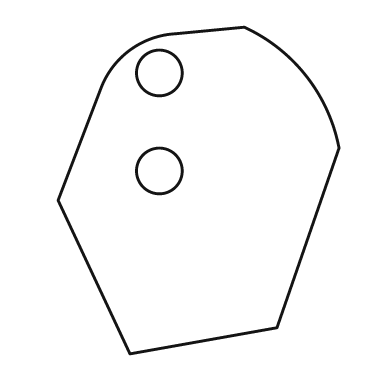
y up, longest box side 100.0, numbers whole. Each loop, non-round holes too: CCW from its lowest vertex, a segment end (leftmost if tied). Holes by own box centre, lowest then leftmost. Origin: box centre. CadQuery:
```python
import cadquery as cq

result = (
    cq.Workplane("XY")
    .moveTo(-21.0, -50.0)
    .lineTo(24.0, -42.0)
    .lineTo(43.0, 13.0)
    .threePointArc((33.0, 35.0), (14.0, 50.0))
    .lineTo(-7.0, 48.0)
    .threePointArc((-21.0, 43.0), (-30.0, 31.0))
    .lineTo(-43.0, -3.0)
    .close()
    .moveTo(-12.0, 6.0)
    .circle(7.0)
    .moveTo(-12.0, 36.0)
    .circle(7.0)
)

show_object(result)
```